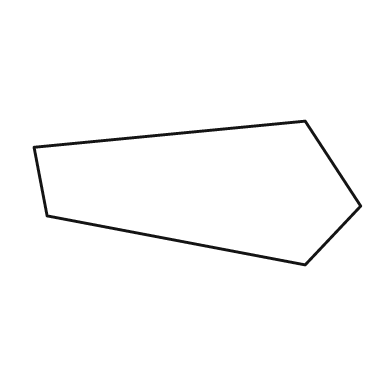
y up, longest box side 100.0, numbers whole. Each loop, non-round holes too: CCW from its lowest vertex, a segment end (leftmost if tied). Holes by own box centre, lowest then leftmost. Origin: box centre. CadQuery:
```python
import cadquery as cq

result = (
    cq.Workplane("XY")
    .moveTo(33.0, -22.0)
    .lineTo(50.0, -4.0)
    .lineTo(33.0, 22.0)
    .lineTo(-50.0, 14.0)
    .lineTo(-46.0, -7.0)
    .close()
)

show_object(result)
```